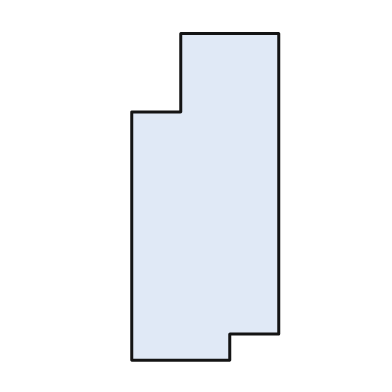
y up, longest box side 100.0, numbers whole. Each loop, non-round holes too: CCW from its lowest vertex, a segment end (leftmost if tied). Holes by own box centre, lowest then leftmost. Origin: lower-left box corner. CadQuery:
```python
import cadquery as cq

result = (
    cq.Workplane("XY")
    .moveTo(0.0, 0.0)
    .lineTo(30.0, 0.0)
    .lineTo(30.0, 8.0)
    .lineTo(45.0, 8.0)
    .lineTo(45.0, 100.0)
    .lineTo(15.0, 100.0)
    .lineTo(15.0, 76.0)
    .lineTo(0.0, 76.0)
    .close()
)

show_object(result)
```